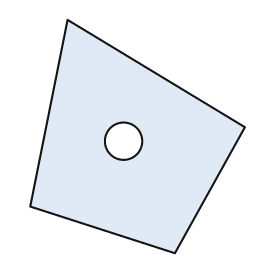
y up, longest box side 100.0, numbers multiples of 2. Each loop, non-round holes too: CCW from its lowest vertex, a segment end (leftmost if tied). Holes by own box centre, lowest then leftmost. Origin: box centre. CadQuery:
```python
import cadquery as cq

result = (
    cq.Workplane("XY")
    .moveTo(16.0, -50.0)
    .lineTo(46.0, 4.0)
    .lineTo(-30.0, 50.0)
    .lineTo(-46.0, -30.0)
    .close()
    .moveTo(-6.0, -2.0)
    .circle(8.0)
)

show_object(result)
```